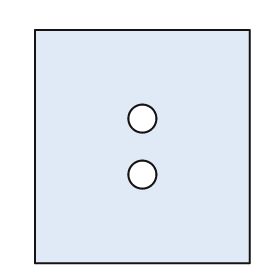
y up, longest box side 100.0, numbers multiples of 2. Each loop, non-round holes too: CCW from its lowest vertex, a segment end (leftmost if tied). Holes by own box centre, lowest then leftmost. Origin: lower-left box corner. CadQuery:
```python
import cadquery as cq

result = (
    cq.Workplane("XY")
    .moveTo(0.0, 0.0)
    .lineTo(92.0, 0.0)
    .lineTo(92.0, 100.0)
    .lineTo(0.0, 100.0)
    .close()
    .moveTo(46.0, 38.0)
    .circle(6.0)
    .moveTo(46.0, 62.0)
    .circle(6.0)
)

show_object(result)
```